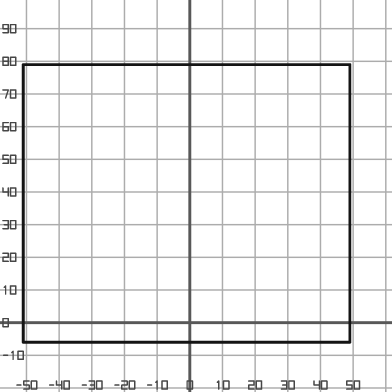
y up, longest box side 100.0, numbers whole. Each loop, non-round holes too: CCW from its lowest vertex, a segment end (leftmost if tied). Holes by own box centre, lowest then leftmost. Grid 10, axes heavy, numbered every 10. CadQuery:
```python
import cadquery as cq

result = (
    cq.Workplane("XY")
    .moveTo(-51.0, -6.0)
    .lineTo(49.0, -6.0)
    .lineTo(49.0, 79.0)
    .lineTo(-51.0, 79.0)
    .close()
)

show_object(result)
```